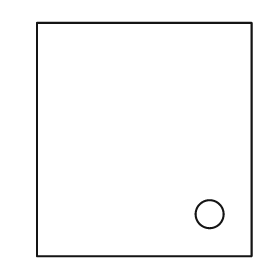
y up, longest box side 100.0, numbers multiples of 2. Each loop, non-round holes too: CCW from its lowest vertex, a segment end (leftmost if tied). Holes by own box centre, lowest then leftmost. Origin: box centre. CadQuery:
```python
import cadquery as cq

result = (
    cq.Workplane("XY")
    .moveTo(-46.0, -50.0)
    .lineTo(46.0, -50.0)
    .lineTo(46.0, 50.0)
    .lineTo(-46.0, 50.0)
    .close()
    .moveTo(28.0, -32.0)
    .circle(6.0)
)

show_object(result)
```